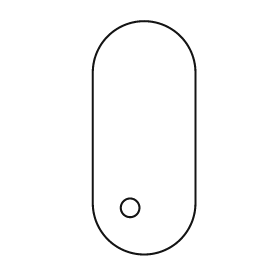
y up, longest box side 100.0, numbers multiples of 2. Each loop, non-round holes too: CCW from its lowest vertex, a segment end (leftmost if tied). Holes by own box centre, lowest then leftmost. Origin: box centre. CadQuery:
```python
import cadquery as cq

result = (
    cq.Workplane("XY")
    .moveTo(-22.0, -28.0)
    .threePointArc((0.0, -50.0), (22.0, -28.0))
    .lineTo(22.0, 28.0)
    .threePointArc((0.0, 50.0), (-22.0, 28.0))
    .close()
    .moveTo(-6.0, -30.0)
    .circle(4.0)
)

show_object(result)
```